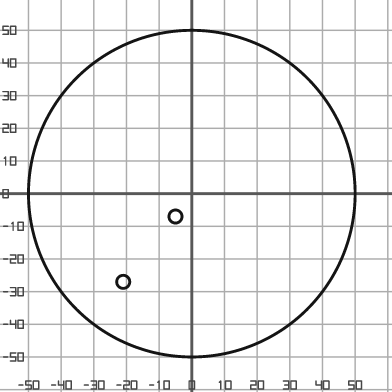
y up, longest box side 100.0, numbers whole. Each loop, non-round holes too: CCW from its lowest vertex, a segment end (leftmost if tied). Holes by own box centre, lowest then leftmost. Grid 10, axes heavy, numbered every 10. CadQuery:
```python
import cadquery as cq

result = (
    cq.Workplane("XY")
    .moveTo(0.0, 0.0)
    .circle(50.0)
    .moveTo(-21.0, -27.0)
    .circle(2.0)
    .moveTo(-5.0, -7.0)
    .circle(2.0)
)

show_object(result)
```